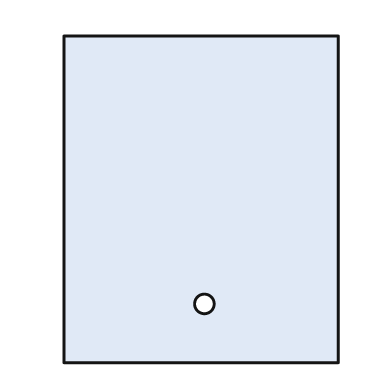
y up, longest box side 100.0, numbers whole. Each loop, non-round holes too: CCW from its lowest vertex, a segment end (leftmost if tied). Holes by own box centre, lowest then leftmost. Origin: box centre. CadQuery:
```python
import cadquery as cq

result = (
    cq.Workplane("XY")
    .moveTo(-42.0, -50.0)
    .lineTo(42.0, -50.0)
    .lineTo(42.0, 50.0)
    .lineTo(-42.0, 50.0)
    .close()
    .moveTo(1.0, -32.0)
    .circle(3.0)
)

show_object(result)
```